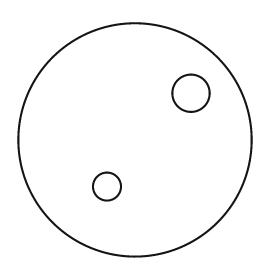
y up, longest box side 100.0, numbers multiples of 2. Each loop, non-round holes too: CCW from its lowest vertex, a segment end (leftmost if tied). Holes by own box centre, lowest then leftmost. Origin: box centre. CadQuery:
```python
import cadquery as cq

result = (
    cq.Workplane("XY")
    .moveTo(0.0, 0.0)
    .circle(50.0)
    .moveTo(-12.0, -20.0)
    .circle(6.0)
    .moveTo(24.0, 20.0)
    .circle(8.0)
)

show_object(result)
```